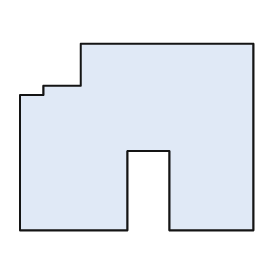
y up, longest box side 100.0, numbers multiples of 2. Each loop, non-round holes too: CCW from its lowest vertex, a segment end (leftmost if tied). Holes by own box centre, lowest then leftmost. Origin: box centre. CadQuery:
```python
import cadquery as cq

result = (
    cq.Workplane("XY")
    .moveTo(-50.0, -40.0)
    .lineTo(-4.0, -40.0)
    .lineTo(-4.0, -6.0)
    .lineTo(14.0, -6.0)
    .lineTo(14.0, -40.0)
    .lineTo(50.0, -40.0)
    .lineTo(50.0, 40.0)
    .lineTo(-24.0, 40.0)
    .lineTo(-24.0, 22.0)
    .lineTo(-40.0, 22.0)
    .lineTo(-40.0, 18.0)
    .lineTo(-50.0, 18.0)
    .close()
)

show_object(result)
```